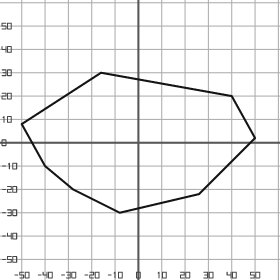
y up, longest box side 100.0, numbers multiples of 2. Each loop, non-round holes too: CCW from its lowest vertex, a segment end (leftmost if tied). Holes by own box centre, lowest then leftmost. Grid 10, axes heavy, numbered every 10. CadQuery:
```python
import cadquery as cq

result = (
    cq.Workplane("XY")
    .moveTo(-8.0, -30.0)
    .lineTo(26.0, -22.0)
    .lineTo(50.0, 2.0)
    .lineTo(40.0, 20.0)
    .lineTo(-16.0, 30.0)
    .lineTo(-50.0, 8.0)
    .lineTo(-40.0, -10.0)
    .lineTo(-28.0, -20.0)
    .close()
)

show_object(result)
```